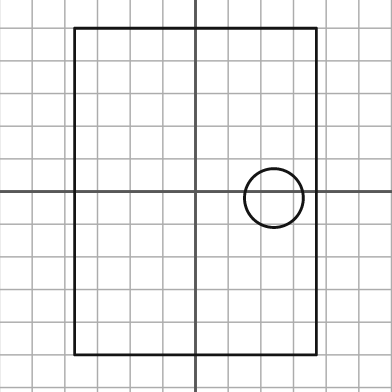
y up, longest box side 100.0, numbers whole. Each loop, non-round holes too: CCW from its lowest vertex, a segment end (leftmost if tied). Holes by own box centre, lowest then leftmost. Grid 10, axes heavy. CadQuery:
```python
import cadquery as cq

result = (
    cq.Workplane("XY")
    .moveTo(-37.0, -50.0)
    .lineTo(37.0, -50.0)
    .lineTo(37.0, 50.0)
    .lineTo(-37.0, 50.0)
    .close()
    .moveTo(24.0, -2.0)
    .circle(9.0)
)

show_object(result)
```